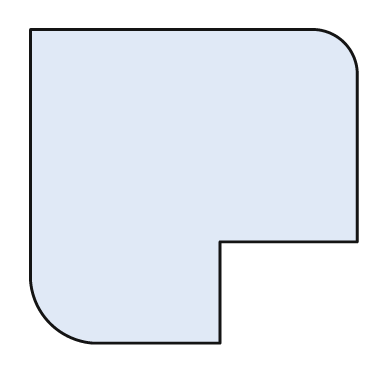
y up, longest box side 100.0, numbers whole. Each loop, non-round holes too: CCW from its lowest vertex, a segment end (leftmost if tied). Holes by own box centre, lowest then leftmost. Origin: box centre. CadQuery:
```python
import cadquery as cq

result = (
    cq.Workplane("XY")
    .moveTo(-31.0, -48.0)
    .lineTo(8.0, -48.0)
    .lineTo(8.0, -17.0)
    .lineTo(50.0, -17.0)
    .lineTo(50.0, 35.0)
    .threePointArc((46.0, 44.0), (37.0, 48.0))
    .lineTo(-50.0, 48.0)
    .lineTo(-50.0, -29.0)
    .threePointArc((-44.0, -42.0), (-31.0, -48.0))
    .close()
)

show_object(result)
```